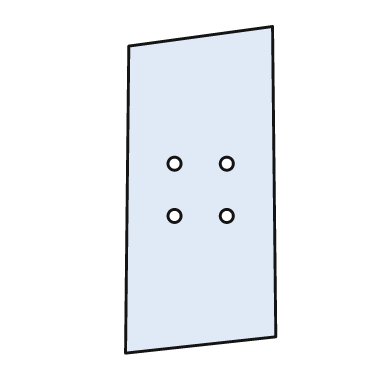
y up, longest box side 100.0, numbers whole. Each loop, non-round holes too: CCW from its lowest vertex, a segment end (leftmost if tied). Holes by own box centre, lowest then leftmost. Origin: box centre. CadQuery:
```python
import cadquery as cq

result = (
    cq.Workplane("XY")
    .moveTo(-23.0, -50.0)
    .lineTo(23.0, -45.0)
    .lineTo(22.0, 50.0)
    .lineTo(-22.0, 44.0)
    .close()
    .moveTo(-8.0, -8.0)
    .circle(2.0)
    .moveTo(8.0, -8.0)
    .circle(2.0)
    .moveTo(-8.0, 8.0)
    .circle(2.0)
    .moveTo(8.0, 8.0)
    .circle(2.0)
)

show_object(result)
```